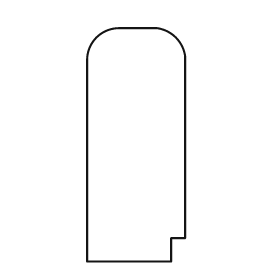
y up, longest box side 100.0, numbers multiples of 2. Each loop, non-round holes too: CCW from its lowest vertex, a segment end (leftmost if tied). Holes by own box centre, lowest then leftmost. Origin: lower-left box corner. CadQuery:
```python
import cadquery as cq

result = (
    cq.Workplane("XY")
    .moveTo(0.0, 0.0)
    .lineTo(36.0, 0.0)
    .lineTo(36.0, 10.0)
    .lineTo(42.0, 10.0)
    .lineTo(42.0, 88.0)
    .threePointArc((38.0, 96.0), (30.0, 100.0))
    .lineTo(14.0, 100.0)
    .threePointArc((4.0, 96.0), (0.0, 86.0))
    .close()
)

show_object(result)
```